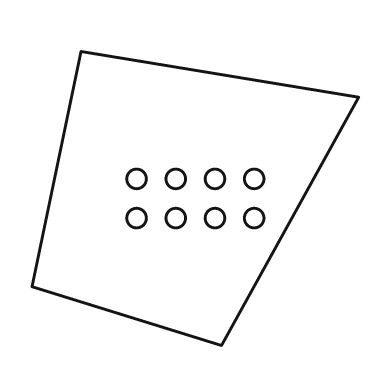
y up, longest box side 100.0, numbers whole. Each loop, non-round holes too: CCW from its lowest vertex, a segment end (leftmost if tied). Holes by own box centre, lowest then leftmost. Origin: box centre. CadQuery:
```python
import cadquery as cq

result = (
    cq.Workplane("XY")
    .moveTo(8.0, -45.0)
    .lineTo(50.0, 31.0)
    .lineTo(-35.0, 45.0)
    .lineTo(-50.0, -27.0)
    .close()
    .moveTo(-18.0, -6.0)
    .circle(3.0)
    .moveTo(-6.0, -6.0)
    .circle(3.0)
    .moveTo(6.0, -6.0)
    .circle(3.0)
    .moveTo(18.0, -6.0)
    .circle(3.0)
    .moveTo(-18.0, 6.0)
    .circle(3.0)
    .moveTo(-6.0, 6.0)
    .circle(3.0)
    .moveTo(6.0, 6.0)
    .circle(3.0)
    .moveTo(18.0, 6.0)
    .circle(3.0)
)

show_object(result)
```